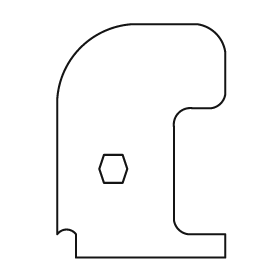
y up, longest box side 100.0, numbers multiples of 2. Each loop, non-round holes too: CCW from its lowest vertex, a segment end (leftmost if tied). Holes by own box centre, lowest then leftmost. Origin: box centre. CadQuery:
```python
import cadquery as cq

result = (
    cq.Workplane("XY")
    .moveTo(-28.0, -50.0)
    .lineTo(36.0, -50.0)
    .lineTo(36.0, -40.0)
    .lineTo(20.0, -40.0)
    .threePointArc((16.0, -38.0), (14.0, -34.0))
    .lineTo(14.0, 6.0)
    .threePointArc((16.0, 12.0), (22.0, 14.0))
    .lineTo(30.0, 14.0)
    .threePointArc((34.0, 16.0), (36.0, 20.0))
    .lineTo(36.0, 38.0)
    .threePointArc((32.0, 46.0), (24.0, 50.0))
    .lineTo(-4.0, 50.0)
    .threePointArc((-26.0, 40.0), (-36.0, 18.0))
    .lineTo(-36.0, -40.0)
    .threePointArc((-32.0, -38.0), (-28.0, -40.0))
    .close()
    .moveTo(-16.0, -18.0)
    .lineTo(-8.0, -18.0)
    .lineTo(-6.0, -12.0)
    .lineTo(-8.0, -6.0)
    .lineTo(-16.0, -6.0)
    .lineTo(-18.0, -12.0)
    .close()
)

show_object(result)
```